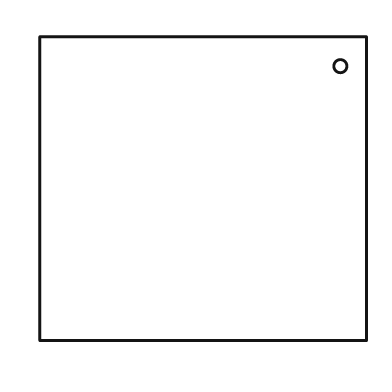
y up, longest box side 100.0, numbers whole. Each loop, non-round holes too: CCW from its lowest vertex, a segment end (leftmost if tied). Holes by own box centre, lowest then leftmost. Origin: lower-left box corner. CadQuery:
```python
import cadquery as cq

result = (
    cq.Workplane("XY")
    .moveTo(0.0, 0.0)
    .lineTo(100.0, 0.0)
    .lineTo(100.0, 93.0)
    .lineTo(0.0, 93.0)
    .close()
    .moveTo(92.0, 84.0)
    .circle(2.0)
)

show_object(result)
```